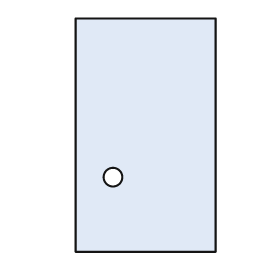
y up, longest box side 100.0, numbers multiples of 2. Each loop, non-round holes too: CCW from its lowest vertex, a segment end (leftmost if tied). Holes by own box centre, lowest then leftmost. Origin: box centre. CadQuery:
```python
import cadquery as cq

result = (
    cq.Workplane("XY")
    .moveTo(-30.0, -50.0)
    .lineTo(30.0, -50.0)
    .lineTo(30.0, 50.0)
    .lineTo(-30.0, 50.0)
    .close()
    .moveTo(-14.0, -18.0)
    .circle(4.0)
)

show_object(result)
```